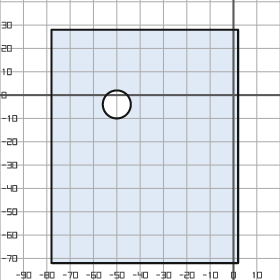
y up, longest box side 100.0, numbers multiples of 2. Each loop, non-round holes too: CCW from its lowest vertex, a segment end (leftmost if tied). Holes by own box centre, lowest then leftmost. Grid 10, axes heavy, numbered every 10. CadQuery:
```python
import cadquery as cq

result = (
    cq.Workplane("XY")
    .moveTo(-78.0, -72.0)
    .lineTo(2.0, -72.0)
    .lineTo(2.0, 28.0)
    .lineTo(-78.0, 28.0)
    .close()
    .moveTo(-50.0, -4.0)
    .circle(6.0)
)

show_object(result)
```